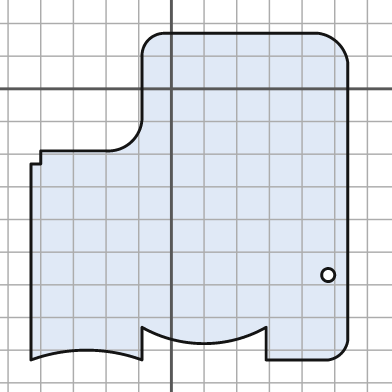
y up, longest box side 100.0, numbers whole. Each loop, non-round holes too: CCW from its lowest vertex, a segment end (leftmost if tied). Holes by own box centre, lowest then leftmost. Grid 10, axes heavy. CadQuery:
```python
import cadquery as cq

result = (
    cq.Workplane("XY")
    .moveTo(-43.0, -83.0)
    .threePointArc((-26.0, -80.0), (-9.0, -83.0))
    .lineTo(-9.0, -73.0)
    .threePointArc((10.0, -78.0), (29.0, -73.0))
    .lineTo(29.0, -83.0)
    .lineTo(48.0, -83.0)
    .threePointArc((52.0, -81.0), (54.0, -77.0))
    .lineTo(54.0, 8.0)
    .threePointArc((51.0, 14.0), (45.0, 17.0))
    .lineTo(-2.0, 17.0)
    .threePointArc((-7.0, 15.0), (-9.0, 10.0))
    .lineTo(-9.0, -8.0)
    .threePointArc((-12.0, -16.0), (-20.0, -19.0))
    .lineTo(-40.0, -19.0)
    .lineTo(-40.0, -23.0)
    .lineTo(-43.0, -23.0)
    .close()
    .moveTo(48.0, -57.0)
    .circle(2.0)
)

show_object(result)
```